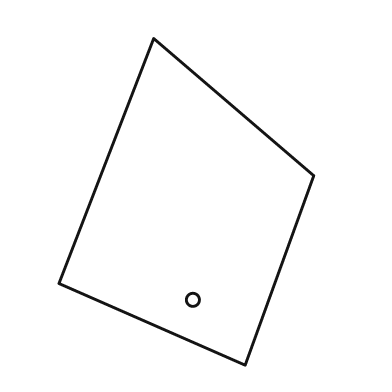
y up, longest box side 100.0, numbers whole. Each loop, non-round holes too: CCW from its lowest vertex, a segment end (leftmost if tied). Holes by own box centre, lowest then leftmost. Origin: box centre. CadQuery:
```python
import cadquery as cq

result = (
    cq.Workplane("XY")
    .moveTo(18.0, -50.0)
    .lineTo(39.0, 8.0)
    .lineTo(-10.0, 50.0)
    .lineTo(-39.0, -25.0)
    .close()
    .moveTo(2.0, -30.0)
    .circle(2.0)
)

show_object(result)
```